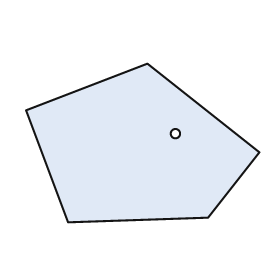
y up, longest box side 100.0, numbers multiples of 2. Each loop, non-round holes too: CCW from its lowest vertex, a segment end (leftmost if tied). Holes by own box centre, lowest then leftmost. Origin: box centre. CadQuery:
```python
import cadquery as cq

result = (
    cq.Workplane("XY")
    .moveTo(-32.0, -34.0)
    .lineTo(28.0, -32.0)
    .lineTo(50.0, -4.0)
    .lineTo(2.0, 34.0)
    .lineTo(-50.0, 14.0)
    .close()
    .moveTo(14.0, 4.0)
    .circle(2.0)
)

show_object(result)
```